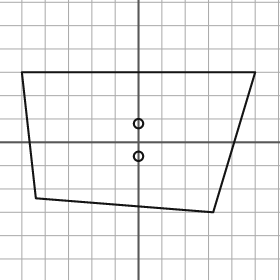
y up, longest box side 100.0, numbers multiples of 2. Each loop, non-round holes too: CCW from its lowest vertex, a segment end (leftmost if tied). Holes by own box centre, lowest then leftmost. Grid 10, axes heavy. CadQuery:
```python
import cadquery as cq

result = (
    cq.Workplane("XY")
    .moveTo(32.0, -30.0)
    .lineTo(50.0, 30.0)
    .lineTo(-50.0, 30.0)
    .lineTo(-44.0, -24.0)
    .close()
    .moveTo(0.0, -6.0)
    .circle(2.0)
    .moveTo(0.0, 8.0)
    .circle(2.0)
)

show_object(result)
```